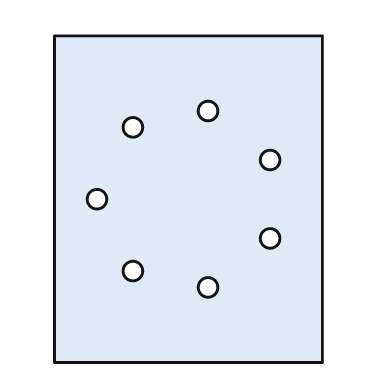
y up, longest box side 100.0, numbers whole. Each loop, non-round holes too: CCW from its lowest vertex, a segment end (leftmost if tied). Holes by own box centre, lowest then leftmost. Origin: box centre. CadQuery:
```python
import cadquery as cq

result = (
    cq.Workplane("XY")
    .moveTo(-41.0, -50.0)
    .lineTo(41.0, -50.0)
    .lineTo(41.0, 50.0)
    .lineTo(-41.0, 50.0)
    .close()
    .moveTo(6.0, -27.0)
    .circle(3.0)
    .moveTo(-17.0, -22.0)
    .circle(3.0)
    .moveTo(25.0, -12.0)
    .circle(3.0)
    .moveTo(-28.0, 0.0)
    .circle(3.0)
    .moveTo(25.0, 12.0)
    .circle(3.0)
    .moveTo(-17.0, 22.0)
    .circle(3.0)
    .moveTo(6.0, 27.0)
    .circle(3.0)
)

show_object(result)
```